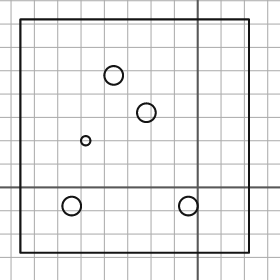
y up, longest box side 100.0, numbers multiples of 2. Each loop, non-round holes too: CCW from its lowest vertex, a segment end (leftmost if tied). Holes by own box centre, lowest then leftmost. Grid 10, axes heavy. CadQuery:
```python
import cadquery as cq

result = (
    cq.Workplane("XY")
    .moveTo(-76.0, -28.0)
    .lineTo(22.0, -28.0)
    .lineTo(22.0, 72.0)
    .lineTo(-76.0, 72.0)
    .close()
    .moveTo(-54.0, -8.0)
    .circle(4.0)
    .moveTo(-4.0, -8.0)
    .circle(4.0)
    .moveTo(-48.0, 20.0)
    .circle(2.0)
    .moveTo(-22.0, 32.0)
    .circle(4.0)
    .moveTo(-36.0, 48.0)
    .circle(4.0)
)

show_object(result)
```